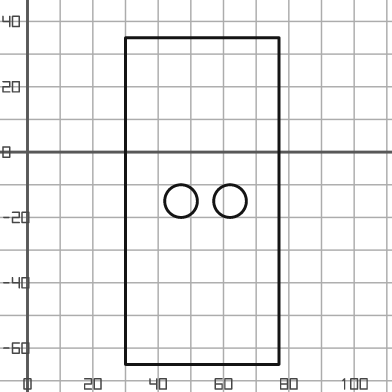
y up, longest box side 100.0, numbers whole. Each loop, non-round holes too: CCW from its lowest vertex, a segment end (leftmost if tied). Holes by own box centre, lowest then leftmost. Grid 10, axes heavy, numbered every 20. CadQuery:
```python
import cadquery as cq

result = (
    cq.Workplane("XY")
    .moveTo(30.0, -65.0)
    .lineTo(77.0, -65.0)
    .lineTo(77.0, 35.0)
    .lineTo(30.0, 35.0)
    .close()
    .moveTo(47.0, -15.0)
    .circle(5.0)
    .moveTo(62.0, -15.0)
    .circle(5.0)
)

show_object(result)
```